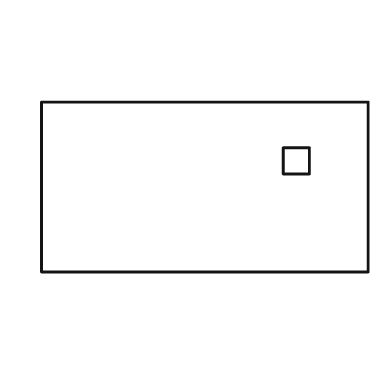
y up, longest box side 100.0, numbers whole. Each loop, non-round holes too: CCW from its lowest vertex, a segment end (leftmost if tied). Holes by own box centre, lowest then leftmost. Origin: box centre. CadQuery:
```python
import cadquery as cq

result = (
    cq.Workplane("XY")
    .moveTo(-50.0, -26.0)
    .lineTo(50.0, -26.0)
    .lineTo(50.0, 26.0)
    .lineTo(-50.0, 26.0)
    .close()
    .moveTo(24.0, 4.0)
    .lineTo(32.0, 4.0)
    .lineTo(32.0, 12.0)
    .lineTo(24.0, 12.0)
    .close()
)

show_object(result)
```